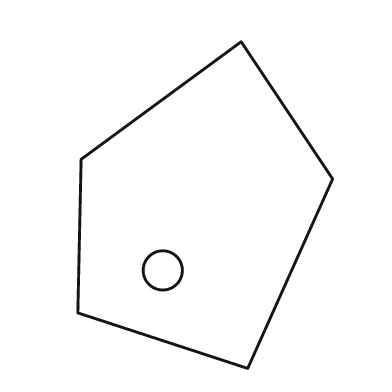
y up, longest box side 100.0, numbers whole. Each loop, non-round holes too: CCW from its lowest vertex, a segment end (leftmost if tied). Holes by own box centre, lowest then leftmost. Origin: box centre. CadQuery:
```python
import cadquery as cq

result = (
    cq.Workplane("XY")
    .moveTo(13.0, -50.0)
    .lineTo(39.0, 8.0)
    .lineTo(11.0, 50.0)
    .lineTo(-38.0, 14.0)
    .lineTo(-39.0, -33.0)
    .close()
    .moveTo(-13.0, -20.0)
    .circle(6.0)
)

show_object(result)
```